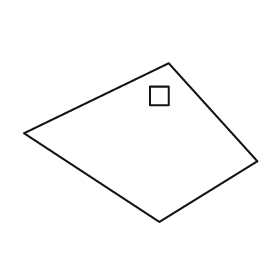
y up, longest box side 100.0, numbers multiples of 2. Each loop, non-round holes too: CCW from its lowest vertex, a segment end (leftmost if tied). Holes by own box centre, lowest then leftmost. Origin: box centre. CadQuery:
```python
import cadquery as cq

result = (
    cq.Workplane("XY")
    .moveTo(8.0, -34.0)
    .lineTo(50.0, -8.0)
    .lineTo(12.0, 34.0)
    .lineTo(-50.0, 4.0)
    .close()
    .moveTo(4.0, 16.0)
    .lineTo(12.0, 16.0)
    .lineTo(12.0, 24.0)
    .lineTo(4.0, 24.0)
    .close()
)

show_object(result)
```